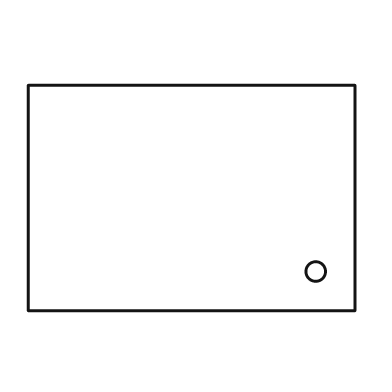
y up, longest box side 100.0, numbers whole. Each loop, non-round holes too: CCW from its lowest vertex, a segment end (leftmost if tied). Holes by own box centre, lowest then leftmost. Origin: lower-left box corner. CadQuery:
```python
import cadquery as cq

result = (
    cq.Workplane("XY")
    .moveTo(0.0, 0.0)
    .lineTo(100.0, 0.0)
    .lineTo(100.0, 69.0)
    .lineTo(0.0, 69.0)
    .close()
    .moveTo(88.0, 12.0)
    .circle(3.0)
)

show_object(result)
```